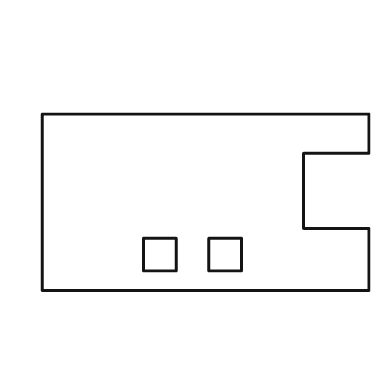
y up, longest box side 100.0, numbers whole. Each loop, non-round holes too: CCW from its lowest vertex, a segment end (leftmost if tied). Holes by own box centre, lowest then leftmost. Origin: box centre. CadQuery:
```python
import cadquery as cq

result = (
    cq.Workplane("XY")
    .moveTo(-50.0, -27.0)
    .lineTo(50.0, -27.0)
    .lineTo(50.0, -8.0)
    .lineTo(30.0, -8.0)
    .lineTo(30.0, 15.0)
    .lineTo(50.0, 15.0)
    .lineTo(50.0, 27.0)
    .lineTo(-50.0, 27.0)
    .close()
    .moveTo(-19.0, -21.0)
    .lineTo(-9.0, -21.0)
    .lineTo(-9.0, -11.0)
    .lineTo(-19.0, -11.0)
    .close()
    .moveTo(1.0, -21.0)
    .lineTo(11.0, -21.0)
    .lineTo(11.0, -11.0)
    .lineTo(1.0, -11.0)
    .close()
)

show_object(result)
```